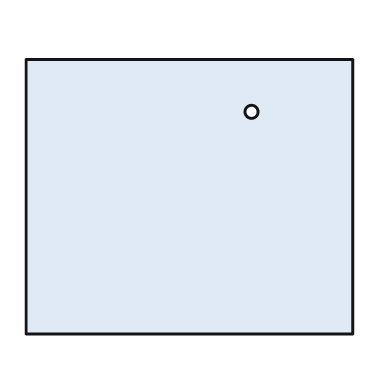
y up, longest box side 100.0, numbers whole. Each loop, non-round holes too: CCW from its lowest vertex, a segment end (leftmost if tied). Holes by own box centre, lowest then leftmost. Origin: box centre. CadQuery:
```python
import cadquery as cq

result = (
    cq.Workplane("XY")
    .moveTo(-50.0, -42.0)
    .lineTo(50.0, -42.0)
    .lineTo(50.0, 42.0)
    .lineTo(-50.0, 42.0)
    .close()
    .moveTo(19.0, 26.0)
    .circle(2.0)
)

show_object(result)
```